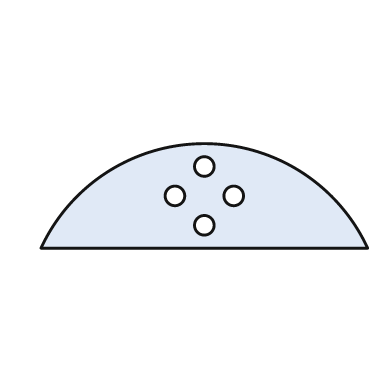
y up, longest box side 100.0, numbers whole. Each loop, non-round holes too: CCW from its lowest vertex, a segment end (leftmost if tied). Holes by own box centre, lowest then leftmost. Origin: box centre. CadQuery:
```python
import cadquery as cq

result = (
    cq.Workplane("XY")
    .moveTo(-50.0, -16.0)
    .lineTo(50.0, -16.0)
    .threePointArc((0.0, 16.0), (-50.0, -16.0))
    .close()
    .moveTo(0.0, -9.0)
    .circle(3.0)
    .moveTo(-9.0, 0.0)
    .circle(3.0)
    .moveTo(9.0, 0.0)
    .circle(3.0)
    .moveTo(0.0, 9.0)
    .circle(3.0)
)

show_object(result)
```